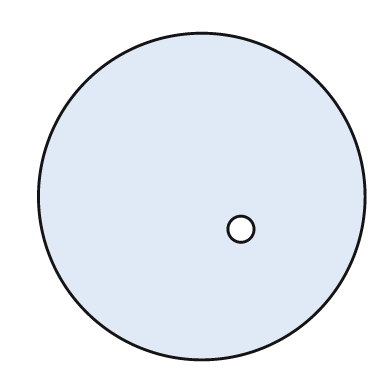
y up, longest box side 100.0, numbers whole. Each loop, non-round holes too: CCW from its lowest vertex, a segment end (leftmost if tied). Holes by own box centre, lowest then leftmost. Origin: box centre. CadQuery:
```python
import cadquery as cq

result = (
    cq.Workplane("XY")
    .moveTo(0.0, 0.0)
    .circle(50.0)
    .moveTo(12.0, -10.0)
    .circle(4.0)
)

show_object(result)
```